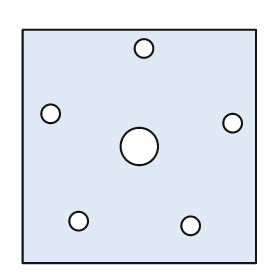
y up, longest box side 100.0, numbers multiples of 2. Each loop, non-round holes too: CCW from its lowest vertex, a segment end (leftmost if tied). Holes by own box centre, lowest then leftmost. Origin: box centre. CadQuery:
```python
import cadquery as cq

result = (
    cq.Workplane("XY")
    .moveTo(-50.0, -50.0)
    .lineTo(50.0, -50.0)
    .lineTo(50.0, 50.0)
    .lineTo(-50.0, 50.0)
    .close()
    .moveTo(22.0, -34.0)
    .circle(4.0)
    .moveTo(-26.0, -32.0)
    .circle(4.0)
    .moveTo(0.0, 0.0)
    .circle(8.0)
    .moveTo(40.0, 10.0)
    .circle(4.0)
    .moveTo(-38.0, 14.0)
    .circle(4.0)
    .moveTo(2.0, 42.0)
    .circle(4.0)
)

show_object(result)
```